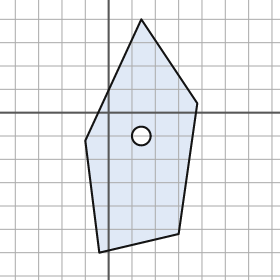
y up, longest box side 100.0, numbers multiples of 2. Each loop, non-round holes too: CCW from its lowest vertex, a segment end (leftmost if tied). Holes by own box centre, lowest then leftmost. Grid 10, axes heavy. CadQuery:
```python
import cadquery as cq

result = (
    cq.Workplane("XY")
    .moveTo(-4.0, -60.0)
    .lineTo(30.0, -52.0)
    .lineTo(38.0, 4.0)
    .lineTo(14.0, 40.0)
    .lineTo(-10.0, -12.0)
    .close()
    .moveTo(14.0, -10.0)
    .circle(4.0)
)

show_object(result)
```